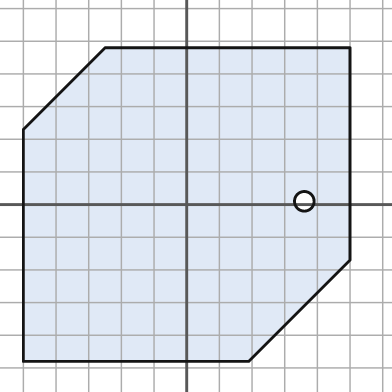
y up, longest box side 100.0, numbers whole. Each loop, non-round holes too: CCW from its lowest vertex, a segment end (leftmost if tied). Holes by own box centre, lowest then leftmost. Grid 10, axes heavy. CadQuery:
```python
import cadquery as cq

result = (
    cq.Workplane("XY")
    .moveTo(-50.0, -48.0)
    .lineTo(19.0, -48.0)
    .lineTo(50.0, -17.0)
    .lineTo(50.0, 48.0)
    .lineTo(-25.0, 48.0)
    .lineTo(-50.0, 23.0)
    .close()
    .moveTo(36.0, 1.0)
    .circle(3.0)
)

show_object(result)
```